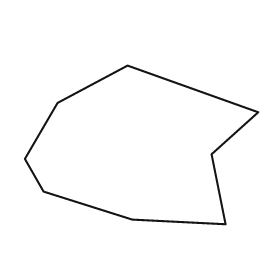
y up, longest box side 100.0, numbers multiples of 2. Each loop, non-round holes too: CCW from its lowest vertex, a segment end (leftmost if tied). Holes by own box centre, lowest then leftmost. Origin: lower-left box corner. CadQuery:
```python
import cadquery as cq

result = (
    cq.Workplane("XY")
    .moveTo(86.0, 0.0)
    .lineTo(80.0, 30.0)
    .lineTo(100.0, 48.0)
    .lineTo(44.0, 68.0)
    .lineTo(14.0, 52.0)
    .lineTo(0.0, 28.0)
    .lineTo(8.0, 14.0)
    .lineTo(46.0, 2.0)
    .close()
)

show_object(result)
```